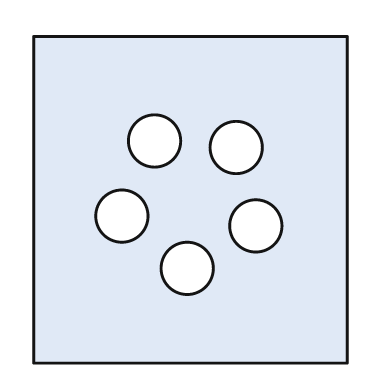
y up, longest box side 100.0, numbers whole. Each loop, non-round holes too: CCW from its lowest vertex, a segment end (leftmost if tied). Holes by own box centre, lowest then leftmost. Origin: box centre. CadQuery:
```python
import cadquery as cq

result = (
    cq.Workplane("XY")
    .moveTo(-48.0, -50.0)
    .lineTo(48.0, -50.0)
    .lineTo(48.0, 50.0)
    .lineTo(-48.0, 50.0)
    .close()
    .moveTo(-1.0, -21.0)
    .circle(8.0)
    .moveTo(20.0, -8.0)
    .circle(8.0)
    .moveTo(-21.0, -5.0)
    .circle(8.0)
    .moveTo(14.0, 16.0)
    .circle(8.0)
    .moveTo(-11.0, 18.0)
    .circle(8.0)
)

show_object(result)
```